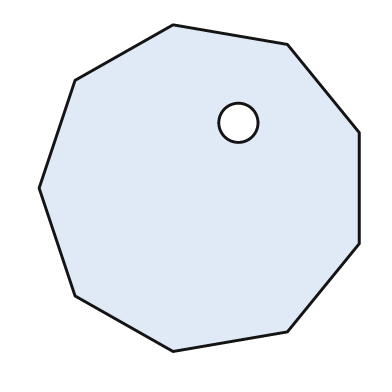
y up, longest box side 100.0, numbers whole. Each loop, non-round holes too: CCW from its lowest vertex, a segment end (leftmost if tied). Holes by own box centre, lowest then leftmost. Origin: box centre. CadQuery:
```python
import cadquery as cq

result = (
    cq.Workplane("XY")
    .moveTo(-8.0, -50.0)
    .lineTo(27.0, -44.0)
    .lineTo(49.0, -17.0)
    .lineTo(49.0, 17.0)
    .lineTo(27.0, 44.0)
    .lineTo(-8.0, 50.0)
    .lineTo(-38.0, 33.0)
    .lineTo(-49.0, 0.0)
    .lineTo(-38.0, -33.0)
    .close()
    .moveTo(12.0, 20.0)
    .circle(6.0)
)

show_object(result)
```